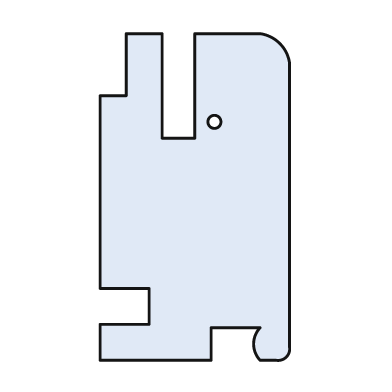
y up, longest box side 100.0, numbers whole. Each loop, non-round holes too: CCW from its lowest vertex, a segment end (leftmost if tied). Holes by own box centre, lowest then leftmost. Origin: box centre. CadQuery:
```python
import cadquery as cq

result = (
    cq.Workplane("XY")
    .moveTo(-29.0, -50.0)
    .lineTo(5.0, -50.0)
    .lineTo(5.0, -40.0)
    .lineTo(20.0, -40.0)
    .threePointArc((18.0, -45.0), (20.0, -50.0))
    .lineTo(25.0, -50.0)
    .threePointArc((28.0, -49.0), (29.0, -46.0))
    .lineTo(29.0, 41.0)
    .threePointArc((26.0, 47.0), (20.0, 50.0))
    .lineTo(0.0, 50.0)
    .lineTo(0.0, 18.0)
    .lineTo(-10.0, 18.0)
    .lineTo(-10.0, 50.0)
    .lineTo(-21.0, 50.0)
    .lineTo(-21.0, 31.0)
    .lineTo(-29.0, 31.0)
    .lineTo(-29.0, -28.0)
    .lineTo(-14.0, -28.0)
    .lineTo(-14.0, -39.0)
    .lineTo(-29.0, -39.0)
    .close()
    .moveTo(6.0, 23.0)
    .circle(2.0)
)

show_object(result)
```